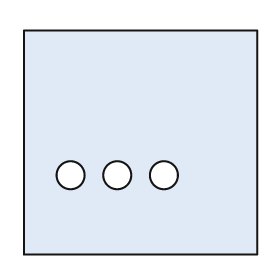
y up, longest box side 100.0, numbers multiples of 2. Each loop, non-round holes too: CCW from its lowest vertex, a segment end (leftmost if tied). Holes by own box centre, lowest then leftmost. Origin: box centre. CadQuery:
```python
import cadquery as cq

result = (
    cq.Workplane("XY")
    .moveTo(-50.0, -48.0)
    .lineTo(50.0, -48.0)
    .lineTo(50.0, 48.0)
    .lineTo(-50.0, 48.0)
    .close()
    .moveTo(-30.0, -14.0)
    .circle(6.0)
    .moveTo(-10.0, -14.0)
    .circle(6.0)
    .moveTo(10.0, -14.0)
    .circle(6.0)
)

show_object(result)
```